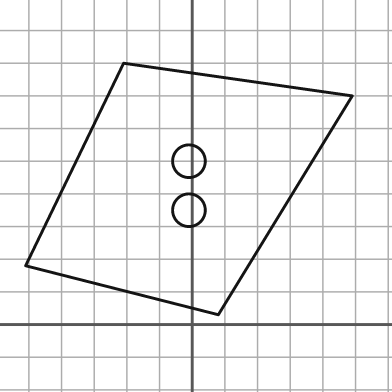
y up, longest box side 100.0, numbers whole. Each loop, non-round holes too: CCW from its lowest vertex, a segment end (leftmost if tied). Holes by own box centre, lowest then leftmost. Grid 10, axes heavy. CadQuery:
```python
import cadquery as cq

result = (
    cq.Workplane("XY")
    .moveTo(8.0, 3.0)
    .lineTo(49.0, 70.0)
    .lineTo(-21.0, 80.0)
    .lineTo(-51.0, 18.0)
    .close()
    .moveTo(-1.0, 35.0)
    .circle(5.0)
    .moveTo(-1.0, 50.0)
    .circle(5.0)
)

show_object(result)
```